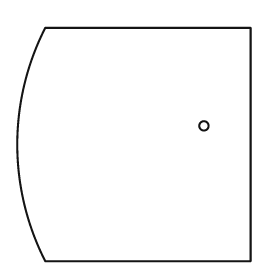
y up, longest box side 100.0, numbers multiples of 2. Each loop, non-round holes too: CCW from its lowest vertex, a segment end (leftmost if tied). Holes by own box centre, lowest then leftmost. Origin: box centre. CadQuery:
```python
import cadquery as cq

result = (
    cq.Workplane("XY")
    .moveTo(-38.0, -50.0)
    .lineTo(50.0, -50.0)
    .lineTo(50.0, 50.0)
    .lineTo(-38.0, 50.0)
    .threePointArc((-50.0, 0.0), (-38.0, -50.0))
    .close()
    .moveTo(30.0, 8.0)
    .circle(2.0)
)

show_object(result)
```